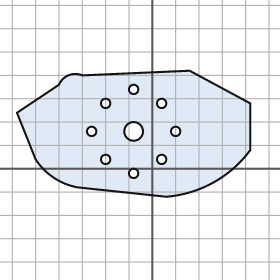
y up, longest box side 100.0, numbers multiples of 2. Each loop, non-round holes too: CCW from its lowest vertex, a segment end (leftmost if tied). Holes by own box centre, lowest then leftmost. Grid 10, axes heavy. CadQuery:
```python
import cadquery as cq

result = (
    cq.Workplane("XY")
    .moveTo(6.0, -12.0)
    .threePointArc((26.0, -6.0), (42.0, 8.0))
    .lineTo(42.0, 28.0)
    .lineTo(16.0, 42.0)
    .lineTo(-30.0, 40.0)
    .threePointArc((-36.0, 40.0), (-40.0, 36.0))
    .lineTo(-58.0, 24.0)
    .lineTo(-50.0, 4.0)
    .threePointArc((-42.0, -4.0), (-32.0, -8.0))
    .close()
    .moveTo(-8.0, -2.0)
    .circle(2.0)
    .moveTo(-20.0, 4.0)
    .circle(2.0)
    .moveTo(4.0, 4.0)
    .circle(2.0)
    .moveTo(-26.0, 16.0)
    .circle(2.0)
    .moveTo(-8.0, 16.0)
    .circle(4.0)
    .moveTo(10.0, 16.0)
    .circle(2.0)
    .moveTo(-20.0, 28.0)
    .circle(2.0)
    .moveTo(4.0, 28.0)
    .circle(2.0)
    .moveTo(-8.0, 34.0)
    .circle(2.0)
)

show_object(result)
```